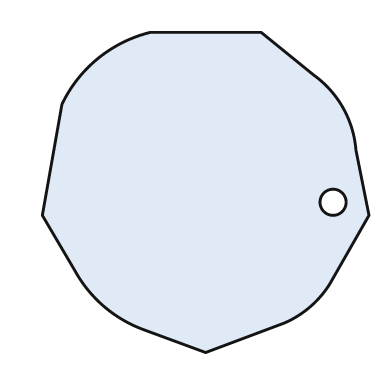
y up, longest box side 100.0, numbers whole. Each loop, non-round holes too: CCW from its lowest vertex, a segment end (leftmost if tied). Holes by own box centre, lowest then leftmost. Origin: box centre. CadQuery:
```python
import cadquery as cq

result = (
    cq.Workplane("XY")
    .moveTo(0.0, -49.0)
    .lineTo(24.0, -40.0)
    .threePointArc((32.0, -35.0), (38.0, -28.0))
    .lineTo(50.0, -7.0)
    .lineTo(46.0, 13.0)
    .threePointArc((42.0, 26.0), (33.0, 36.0))
    .lineTo(17.0, 49.0)
    .lineTo(-17.0, 49.0)
    .threePointArc((-33.0, 41.0), (-44.0, 27.0))
    .lineTo(-50.0, -7.0)
    .lineTo(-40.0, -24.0)
    .threePointArc((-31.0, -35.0), (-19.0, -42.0))
    .close()
    .moveTo(39.0, -3.0)
    .circle(4.0)
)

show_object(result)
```